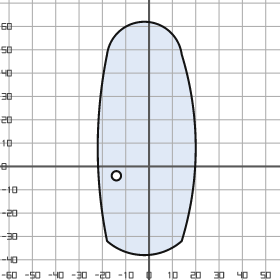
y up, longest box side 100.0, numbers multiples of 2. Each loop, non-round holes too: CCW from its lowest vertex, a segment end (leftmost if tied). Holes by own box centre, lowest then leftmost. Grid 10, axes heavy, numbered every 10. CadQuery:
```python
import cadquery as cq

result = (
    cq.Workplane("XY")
    .moveTo(-18.0, -32.0)
    .threePointArc((-2.0, -38.0), (14.0, -32.0))
    .threePointArc((20.0, 8.0), (14.0, 48.0))
    .threePointArc((-2.0, 62.0), (-18.0, 48.0))
    .threePointArc((-22.0, 8.0), (-18.0, -32.0))
    .close()
    .moveTo(-14.0, -4.0)
    .circle(2.0)
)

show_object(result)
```